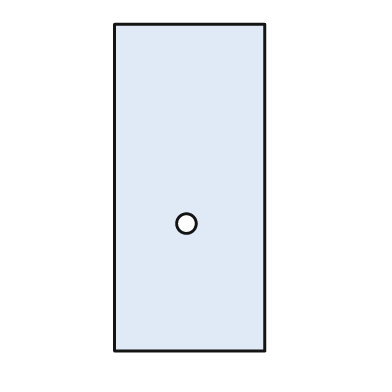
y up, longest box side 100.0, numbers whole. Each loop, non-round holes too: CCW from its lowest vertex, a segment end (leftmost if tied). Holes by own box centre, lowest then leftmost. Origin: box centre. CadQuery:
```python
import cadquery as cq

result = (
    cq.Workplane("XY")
    .moveTo(-23.0, -50.0)
    .lineTo(23.0, -50.0)
    .lineTo(23.0, 50.0)
    .lineTo(-23.0, 50.0)
    .close()
    .moveTo(-1.0, -11.0)
    .circle(3.0)
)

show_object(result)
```